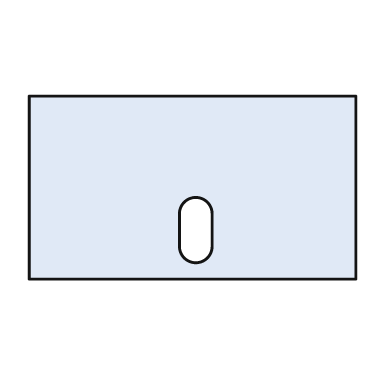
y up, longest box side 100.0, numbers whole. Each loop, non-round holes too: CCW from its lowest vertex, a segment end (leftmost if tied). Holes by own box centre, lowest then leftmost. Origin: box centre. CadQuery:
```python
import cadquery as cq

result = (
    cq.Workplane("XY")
    .moveTo(-50.0, -28.0)
    .lineTo(50.0, -28.0)
    .lineTo(50.0, 28.0)
    .lineTo(-50.0, 28.0)
    .close()
    .moveTo(-4.0, -18.0)
    .threePointArc((1.0, -23.0), (6.0, -18.0))
    .lineTo(6.0, -8.0)
    .threePointArc((1.0, -3.0), (-4.0, -8.0))
    .close()
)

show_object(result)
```